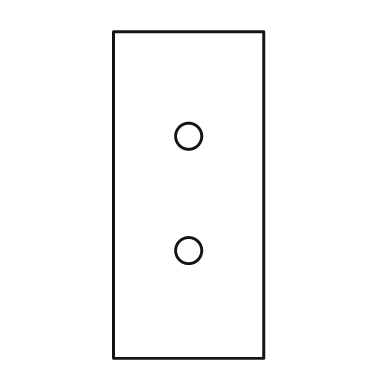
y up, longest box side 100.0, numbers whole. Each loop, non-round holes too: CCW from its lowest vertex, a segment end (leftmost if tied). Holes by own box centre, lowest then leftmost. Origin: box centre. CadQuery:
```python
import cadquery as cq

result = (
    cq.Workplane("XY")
    .moveTo(-23.0, -50.0)
    .lineTo(23.0, -50.0)
    .lineTo(23.0, 50.0)
    .lineTo(-23.0, 50.0)
    .close()
    .moveTo(0.0, -17.0)
    .circle(4.0)
    .moveTo(0.0, 18.0)
    .circle(4.0)
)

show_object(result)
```